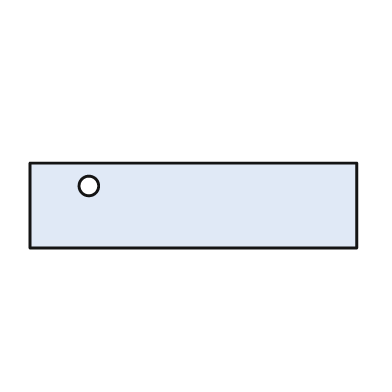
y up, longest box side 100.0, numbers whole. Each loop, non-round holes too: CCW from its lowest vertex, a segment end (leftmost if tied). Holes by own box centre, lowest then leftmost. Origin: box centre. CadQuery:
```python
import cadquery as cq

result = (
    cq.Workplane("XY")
    .moveTo(-50.0, -13.0)
    .lineTo(50.0, -13.0)
    .lineTo(50.0, 13.0)
    .lineTo(-50.0, 13.0)
    .close()
    .moveTo(-32.0, 6.0)
    .circle(3.0)
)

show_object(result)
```